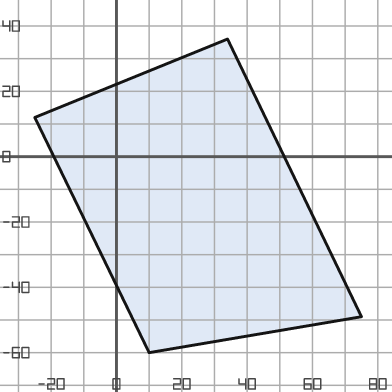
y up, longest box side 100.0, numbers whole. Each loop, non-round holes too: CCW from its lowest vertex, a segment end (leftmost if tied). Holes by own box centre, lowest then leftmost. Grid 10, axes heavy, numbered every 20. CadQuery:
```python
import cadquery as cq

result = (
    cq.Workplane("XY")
    .moveTo(10.0, -60.0)
    .lineTo(75.0, -49.0)
    .lineTo(34.0, 36.0)
    .lineTo(-25.0, 12.0)
    .close()
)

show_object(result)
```